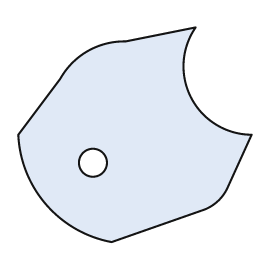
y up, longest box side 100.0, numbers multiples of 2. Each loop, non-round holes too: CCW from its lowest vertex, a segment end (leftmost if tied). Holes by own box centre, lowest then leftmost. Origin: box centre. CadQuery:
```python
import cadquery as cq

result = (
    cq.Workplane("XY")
    .moveTo(-10.0, -46.0)
    .lineTo(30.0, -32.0)
    .threePointArc((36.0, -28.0), (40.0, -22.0))
    .lineTo(50.0, 0.0)
    .threePointArc((24.0, 16.0), (26.0, 46.0))
    .lineTo(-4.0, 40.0)
    .threePointArc((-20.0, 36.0), (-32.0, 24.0))
    .lineTo(-50.0, 0.0)
    .threePointArc((-38.0, -30.0), (-10.0, -46.0))
    .close()
    .moveTo(-18.0, -12.0)
    .circle(6.0)
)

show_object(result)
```